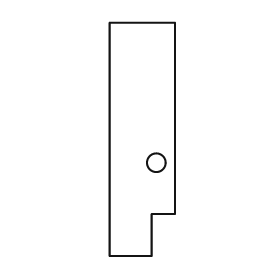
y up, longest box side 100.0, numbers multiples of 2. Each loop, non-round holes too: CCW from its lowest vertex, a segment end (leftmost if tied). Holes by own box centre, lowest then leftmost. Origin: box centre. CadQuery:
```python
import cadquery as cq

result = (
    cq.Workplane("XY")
    .moveTo(-14.0, -50.0)
    .lineTo(4.0, -50.0)
    .lineTo(4.0, -32.0)
    .lineTo(14.0, -32.0)
    .lineTo(14.0, 50.0)
    .lineTo(-14.0, 50.0)
    .close()
    .moveTo(6.0, -10.0)
    .circle(4.0)
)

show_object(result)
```